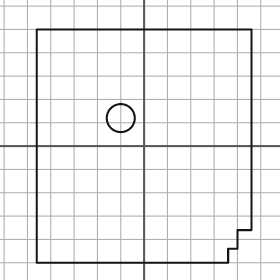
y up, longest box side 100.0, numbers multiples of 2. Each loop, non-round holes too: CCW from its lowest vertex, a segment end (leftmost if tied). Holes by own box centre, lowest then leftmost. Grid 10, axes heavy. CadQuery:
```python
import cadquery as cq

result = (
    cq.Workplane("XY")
    .moveTo(-46.0, -50.0)
    .lineTo(36.0, -50.0)
    .lineTo(36.0, -44.0)
    .lineTo(40.0, -44.0)
    .lineTo(40.0, -36.0)
    .lineTo(46.0, -36.0)
    .lineTo(46.0, 50.0)
    .lineTo(-46.0, 50.0)
    .close()
    .moveTo(-10.0, 12.0)
    .circle(6.0)
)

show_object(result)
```